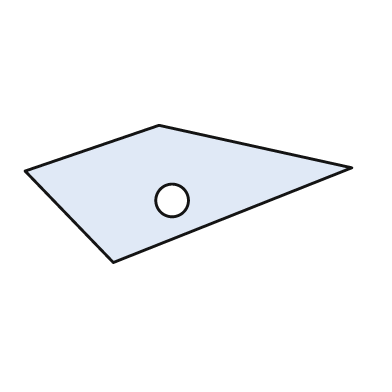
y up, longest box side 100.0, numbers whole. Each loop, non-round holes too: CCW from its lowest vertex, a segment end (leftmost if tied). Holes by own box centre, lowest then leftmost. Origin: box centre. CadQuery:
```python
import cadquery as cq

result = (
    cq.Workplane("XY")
    .moveTo(-23.0, -21.0)
    .lineTo(50.0, 8.0)
    .lineTo(-9.0, 21.0)
    .lineTo(-50.0, 7.0)
    .close()
    .moveTo(-5.0, -2.0)
    .circle(5.0)
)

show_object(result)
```